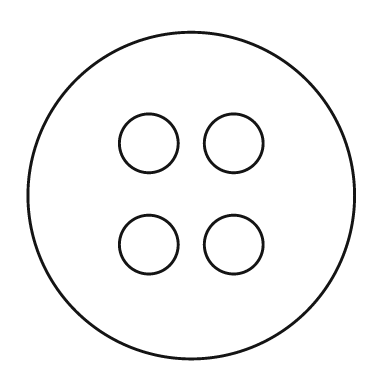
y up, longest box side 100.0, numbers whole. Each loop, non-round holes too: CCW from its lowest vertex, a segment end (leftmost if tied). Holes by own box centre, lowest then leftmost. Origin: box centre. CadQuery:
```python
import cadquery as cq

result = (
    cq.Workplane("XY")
    .moveTo(0.0, 0.0)
    .circle(50.0)
    .moveTo(-13.0, -15.0)
    .circle(9.0)
    .moveTo(13.0, -15.0)
    .circle(9.0)
    .moveTo(-13.0, 16.0)
    .circle(9.0)
    .moveTo(13.0, 16.0)
    .circle(9.0)
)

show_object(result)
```